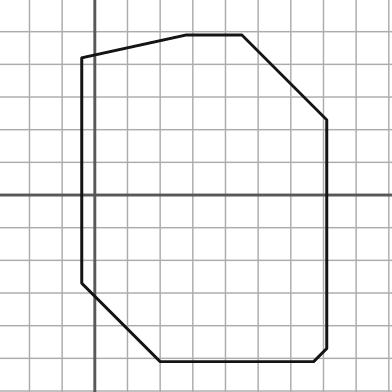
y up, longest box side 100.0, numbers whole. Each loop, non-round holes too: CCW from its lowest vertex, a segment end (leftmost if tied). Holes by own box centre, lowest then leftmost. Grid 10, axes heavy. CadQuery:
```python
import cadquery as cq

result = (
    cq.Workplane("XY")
    .moveTo(20.0, -51.0)
    .lineTo(67.0, -51.0)
    .lineTo(71.0, -47.0)
    .lineTo(71.0, 23.0)
    .lineTo(45.0, 49.0)
    .lineTo(28.0, 49.0)
    .lineTo(-4.0, 42.0)
    .lineTo(-4.0, -27.0)
    .close()
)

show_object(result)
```